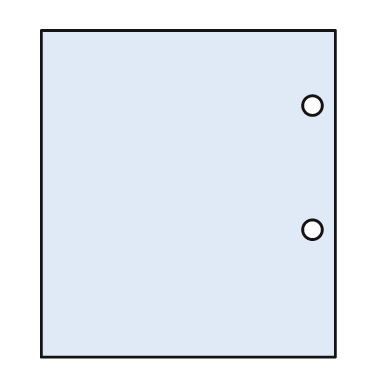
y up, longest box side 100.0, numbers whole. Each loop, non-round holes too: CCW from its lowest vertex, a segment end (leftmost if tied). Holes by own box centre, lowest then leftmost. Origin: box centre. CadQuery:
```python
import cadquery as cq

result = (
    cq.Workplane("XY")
    .moveTo(-45.0, -50.0)
    .lineTo(45.0, -50.0)
    .lineTo(45.0, 50.0)
    .lineTo(-45.0, 50.0)
    .close()
    .moveTo(38.0, -11.0)
    .circle(3.0)
    .moveTo(38.0, 27.0)
    .circle(3.0)
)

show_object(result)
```